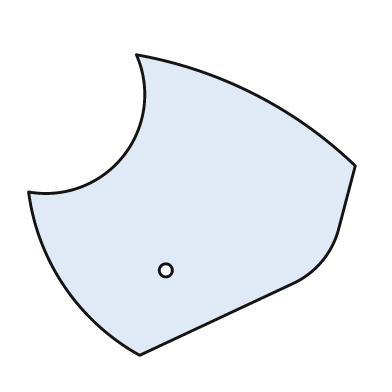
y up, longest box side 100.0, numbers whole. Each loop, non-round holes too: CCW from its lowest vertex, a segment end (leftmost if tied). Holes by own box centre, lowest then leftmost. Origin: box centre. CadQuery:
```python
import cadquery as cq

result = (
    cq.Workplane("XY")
    .moveTo(-16.0, -46.0)
    .lineTo(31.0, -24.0)
    .threePointArc((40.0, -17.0), (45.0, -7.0))
    .lineTo(50.0, 12.0)
    .threePointArc((19.0, 34.0), (-17.0, 46.0))
    .threePointArc((-21.0, 15.0), (-50.0, 4.0))
    .threePointArc((-39.0, -25.0), (-16.0, -46.0))
    .close()
    .moveTo(-8.0, -20.0)
    .circle(2.0)
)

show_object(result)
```